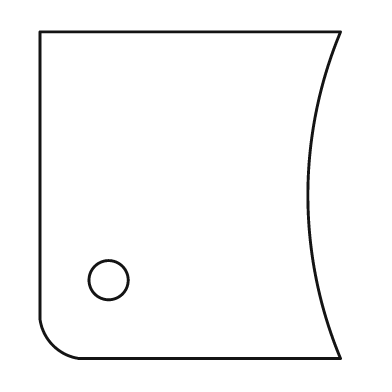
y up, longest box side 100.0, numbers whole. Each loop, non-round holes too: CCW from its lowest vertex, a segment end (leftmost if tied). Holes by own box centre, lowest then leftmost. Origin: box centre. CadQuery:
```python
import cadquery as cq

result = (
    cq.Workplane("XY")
    .moveTo(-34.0, -50.0)
    .lineTo(46.0, -50.0)
    .threePointArc((36.0, 0.0), (46.0, 50.0))
    .lineTo(-46.0, 50.0)
    .lineTo(-46.0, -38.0)
    .threePointArc((-42.0, -46.0), (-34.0, -50.0))
    .close()
    .moveTo(-25.0, -26.0)
    .circle(6.0)
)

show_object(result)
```